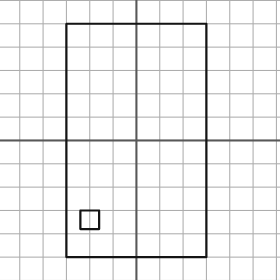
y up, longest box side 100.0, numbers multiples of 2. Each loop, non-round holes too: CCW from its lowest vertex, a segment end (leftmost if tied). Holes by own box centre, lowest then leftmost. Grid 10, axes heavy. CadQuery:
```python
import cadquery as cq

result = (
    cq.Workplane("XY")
    .moveTo(-30.0, -50.0)
    .lineTo(30.0, -50.0)
    .lineTo(30.0, 50.0)
    .lineTo(-30.0, 50.0)
    .close()
    .moveTo(-24.0, -38.0)
    .lineTo(-16.0, -38.0)
    .lineTo(-16.0, -30.0)
    .lineTo(-24.0, -30.0)
    .close()
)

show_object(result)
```